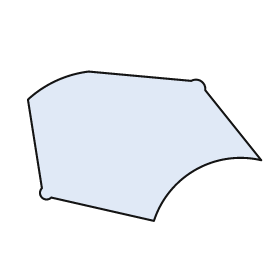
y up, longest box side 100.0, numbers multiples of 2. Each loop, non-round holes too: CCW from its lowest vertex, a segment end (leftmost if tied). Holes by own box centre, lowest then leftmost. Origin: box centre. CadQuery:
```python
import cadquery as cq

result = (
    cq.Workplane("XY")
    .moveTo(4.0, -32.0)
    .threePointArc((22.0, -10.0), (50.0, -6.0))
    .lineTo(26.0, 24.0)
    .threePointArc((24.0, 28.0), (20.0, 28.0))
    .lineTo(-24.0, 32.0)
    .threePointArc((-38.0, 28.0), (-50.0, 20.0))
    .lineTo(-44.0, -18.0)
    .threePointArc((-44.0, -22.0), (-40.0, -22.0))
    .close()
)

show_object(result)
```